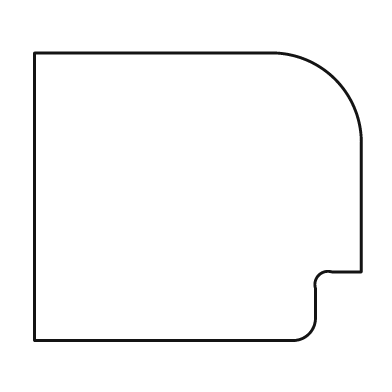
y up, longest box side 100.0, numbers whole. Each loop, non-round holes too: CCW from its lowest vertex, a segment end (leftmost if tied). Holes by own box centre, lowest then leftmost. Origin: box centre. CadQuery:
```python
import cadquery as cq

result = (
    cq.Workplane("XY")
    .moveTo(-50.0, -44.0)
    .lineTo(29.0, -44.0)
    .threePointArc((34.0, -42.0), (36.0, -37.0))
    .lineTo(36.0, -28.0)
    .threePointArc((37.0, -24.0), (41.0, -23.0))
    .lineTo(50.0, -23.0)
    .lineTo(50.0, 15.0)
    .threePointArc((42.0, 36.0), (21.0, 44.0))
    .lineTo(-50.0, 44.0)
    .close()
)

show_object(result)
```